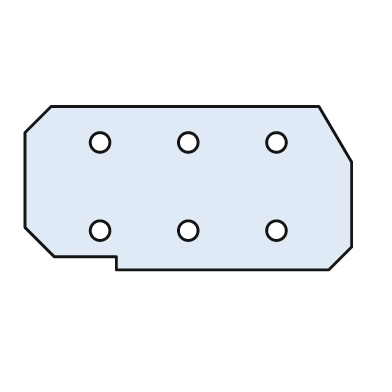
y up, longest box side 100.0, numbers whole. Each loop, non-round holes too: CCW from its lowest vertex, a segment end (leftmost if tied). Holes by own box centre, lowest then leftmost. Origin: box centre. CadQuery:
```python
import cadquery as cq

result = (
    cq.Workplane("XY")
    .moveTo(-22.0, -25.0)
    .lineTo(43.0, -25.0)
    .lineTo(50.0, -18.0)
    .lineTo(50.0, 8.0)
    .lineTo(40.0, 25.0)
    .lineTo(-42.0, 25.0)
    .lineTo(-50.0, 17.0)
    .lineTo(-50.0, -12.0)
    .lineTo(-41.0, -21.0)
    .lineTo(-22.0, -21.0)
    .close()
    .moveTo(-27.0, -13.0)
    .circle(3.0)
    .moveTo(0.0, -13.0)
    .circle(3.0)
    .moveTo(27.0, -13.0)
    .circle(3.0)
    .moveTo(-27.0, 14.0)
    .circle(3.0)
    .moveTo(0.0, 14.0)
    .circle(3.0)
    .moveTo(27.0, 14.0)
    .circle(3.0)
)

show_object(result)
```